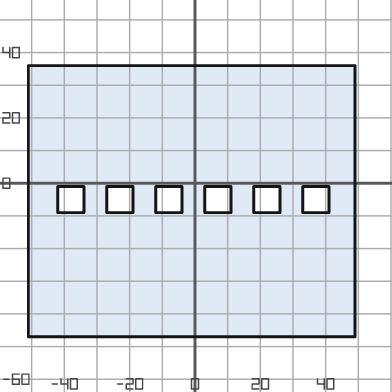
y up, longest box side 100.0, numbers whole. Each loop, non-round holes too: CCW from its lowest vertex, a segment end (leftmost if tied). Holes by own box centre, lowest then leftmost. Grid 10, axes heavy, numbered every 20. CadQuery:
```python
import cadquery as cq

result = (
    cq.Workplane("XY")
    .moveTo(-51.0, -47.0)
    .lineTo(49.0, -47.0)
    .lineTo(49.0, 36.0)
    .lineTo(-51.0, 36.0)
    .close()
    .moveTo(-42.0, -9.0)
    .lineTo(-34.0, -9.0)
    .lineTo(-34.0, -1.0)
    .lineTo(-42.0, -1.0)
    .close()
    .moveTo(-27.0, -9.0)
    .lineTo(-19.0, -9.0)
    .lineTo(-19.0, -1.0)
    .lineTo(-27.0, -1.0)
    .close()
    .moveTo(-12.0, -9.0)
    .lineTo(-4.0, -9.0)
    .lineTo(-4.0, -1.0)
    .lineTo(-12.0, -1.0)
    .close()
    .moveTo(3.0, -9.0)
    .lineTo(11.0, -9.0)
    .lineTo(11.0, -1.0)
    .lineTo(3.0, -1.0)
    .close()
    .moveTo(18.0, -9.0)
    .lineTo(26.0, -9.0)
    .lineTo(26.0, -1.0)
    .lineTo(18.0, -1.0)
    .close()
    .moveTo(33.0, -9.0)
    .lineTo(41.0, -9.0)
    .lineTo(41.0, -1.0)
    .lineTo(33.0, -1.0)
    .close()
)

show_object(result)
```